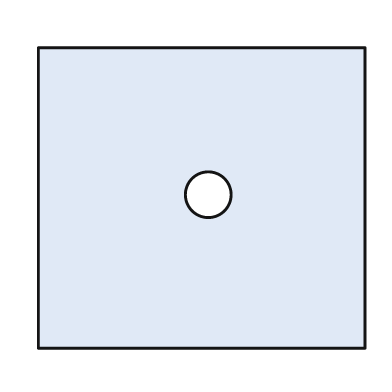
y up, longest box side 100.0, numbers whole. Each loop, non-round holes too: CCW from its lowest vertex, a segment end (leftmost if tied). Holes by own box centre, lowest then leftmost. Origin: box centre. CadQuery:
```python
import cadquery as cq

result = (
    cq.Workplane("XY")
    .moveTo(-50.0, -46.0)
    .lineTo(50.0, -46.0)
    .lineTo(50.0, 46.0)
    .lineTo(-50.0, 46.0)
    .close()
    .moveTo(2.0, 1.0)
    .circle(7.0)
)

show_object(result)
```